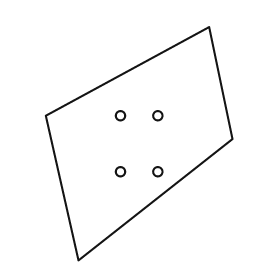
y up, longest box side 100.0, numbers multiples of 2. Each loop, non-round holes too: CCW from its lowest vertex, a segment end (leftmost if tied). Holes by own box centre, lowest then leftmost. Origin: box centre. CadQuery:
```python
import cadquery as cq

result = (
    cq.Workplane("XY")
    .moveTo(-26.0, -50.0)
    .lineTo(40.0, 2.0)
    .lineTo(30.0, 50.0)
    .lineTo(-40.0, 12.0)
    .close()
    .moveTo(-8.0, -12.0)
    .circle(2.0)
    .moveTo(8.0, -12.0)
    .circle(2.0)
    .moveTo(-8.0, 12.0)
    .circle(2.0)
    .moveTo(8.0, 12.0)
    .circle(2.0)
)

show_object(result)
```